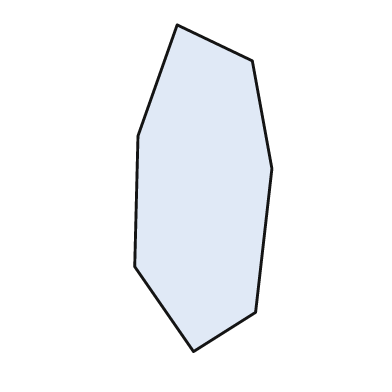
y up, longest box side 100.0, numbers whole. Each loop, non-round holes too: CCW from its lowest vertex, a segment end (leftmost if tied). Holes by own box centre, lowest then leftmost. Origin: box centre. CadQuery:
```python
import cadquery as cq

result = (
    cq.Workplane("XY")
    .moveTo(-3.0, -50.0)
    .lineTo(16.0, -38.0)
    .lineTo(21.0, 6.0)
    .lineTo(15.0, 39.0)
    .lineTo(-8.0, 50.0)
    .lineTo(-20.0, 16.0)
    .lineTo(-21.0, -24.0)
    .close()
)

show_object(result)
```